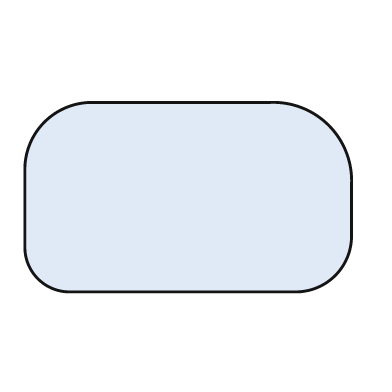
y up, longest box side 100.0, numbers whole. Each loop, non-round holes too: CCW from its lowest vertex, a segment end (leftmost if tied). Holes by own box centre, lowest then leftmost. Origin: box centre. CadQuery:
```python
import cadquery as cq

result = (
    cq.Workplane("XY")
    .moveTo(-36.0, -29.0)
    .lineTo(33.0, -29.0)
    .threePointArc((45.0, -24.0), (50.0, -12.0))
    .lineTo(50.0, 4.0)
    .threePointArc((43.0, 22.0), (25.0, 29.0))
    .lineTo(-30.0, 29.0)
    .threePointArc((-44.0, 23.0), (-50.0, 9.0))
    .lineTo(-50.0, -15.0)
    .threePointArc((-46.0, -25.0), (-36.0, -29.0))
    .close()
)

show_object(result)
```